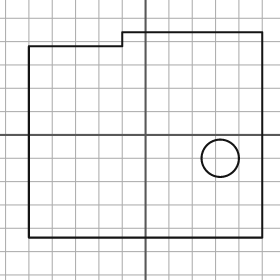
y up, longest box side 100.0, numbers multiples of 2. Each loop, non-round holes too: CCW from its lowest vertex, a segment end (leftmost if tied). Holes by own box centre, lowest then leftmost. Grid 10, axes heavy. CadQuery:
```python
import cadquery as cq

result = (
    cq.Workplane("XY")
    .moveTo(-50.0, -44.0)
    .lineTo(50.0, -44.0)
    .lineTo(50.0, 44.0)
    .lineTo(-10.0, 44.0)
    .lineTo(-10.0, 38.0)
    .lineTo(-50.0, 38.0)
    .close()
    .moveTo(32.0, -10.0)
    .circle(8.0)
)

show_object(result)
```